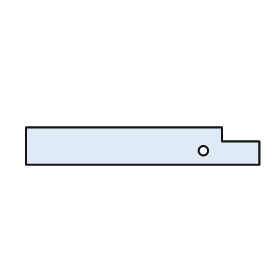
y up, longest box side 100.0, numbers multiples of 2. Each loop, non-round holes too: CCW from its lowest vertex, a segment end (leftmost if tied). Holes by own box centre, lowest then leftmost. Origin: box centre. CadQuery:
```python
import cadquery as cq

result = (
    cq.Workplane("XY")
    .moveTo(-50.0, -8.0)
    .lineTo(50.0, -8.0)
    .lineTo(50.0, 2.0)
    .lineTo(34.0, 2.0)
    .lineTo(34.0, 8.0)
    .lineTo(-50.0, 8.0)
    .close()
    .moveTo(26.0, -2.0)
    .circle(2.0)
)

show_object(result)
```